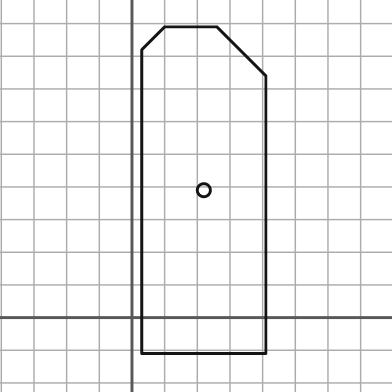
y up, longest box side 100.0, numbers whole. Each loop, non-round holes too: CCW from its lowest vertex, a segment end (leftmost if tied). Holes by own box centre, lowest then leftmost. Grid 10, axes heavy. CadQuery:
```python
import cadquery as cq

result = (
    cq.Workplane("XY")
    .moveTo(3.0, -11.0)
    .lineTo(41.0, -11.0)
    .lineTo(41.0, 74.0)
    .lineTo(26.0, 89.0)
    .lineTo(10.0, 89.0)
    .lineTo(3.0, 82.0)
    .close()
    .moveTo(22.0, 39.0)
    .circle(2.0)
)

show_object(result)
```